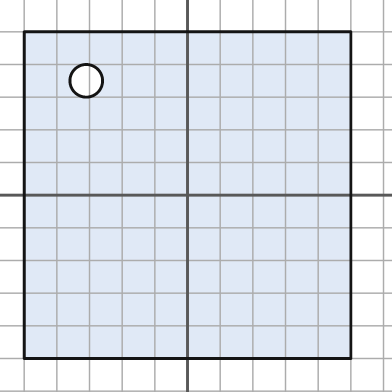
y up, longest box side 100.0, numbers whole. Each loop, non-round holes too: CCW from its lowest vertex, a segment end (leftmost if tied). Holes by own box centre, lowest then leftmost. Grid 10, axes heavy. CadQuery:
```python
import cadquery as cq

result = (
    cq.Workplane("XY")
    .moveTo(-50.0, -50.0)
    .lineTo(50.0, -50.0)
    .lineTo(50.0, 50.0)
    .lineTo(-50.0, 50.0)
    .close()
    .moveTo(-31.0, 35.0)
    .circle(5.0)
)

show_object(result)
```